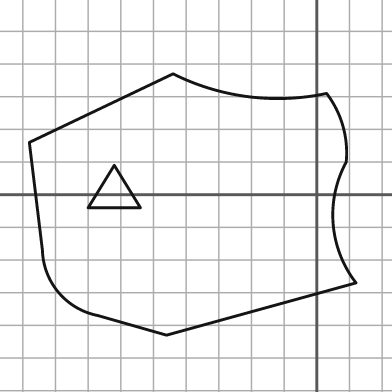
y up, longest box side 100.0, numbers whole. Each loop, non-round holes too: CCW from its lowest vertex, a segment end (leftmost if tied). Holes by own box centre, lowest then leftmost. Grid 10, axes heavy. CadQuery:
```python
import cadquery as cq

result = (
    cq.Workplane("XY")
    .moveTo(-46.0, -43.0)
    .lineTo(12.0, -27.0)
    .threePointArc((5.0, -9.0), (9.0, 10.0))
    .threePointArc((8.0, 21.0), (3.0, 31.0))
    .threePointArc((-21.0, 30.0), (-44.0, 37.0))
    .lineTo(-88.0, 16.0)
    .lineTo(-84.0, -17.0)
    .threePointArc((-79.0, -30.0), (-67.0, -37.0))
    .close()
    .moveTo(-70.0, -4.0)
    .lineTo(-54.0, -4.0)
    .lineTo(-62.0, 9.0)
    .close()
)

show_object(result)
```